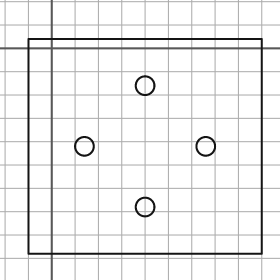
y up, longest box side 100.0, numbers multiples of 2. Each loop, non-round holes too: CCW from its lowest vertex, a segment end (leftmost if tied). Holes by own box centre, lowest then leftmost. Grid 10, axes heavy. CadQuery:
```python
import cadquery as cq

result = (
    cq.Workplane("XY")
    .moveTo(-10.0, -88.0)
    .lineTo(90.0, -88.0)
    .lineTo(90.0, 4.0)
    .lineTo(-10.0, 4.0)
    .close()
    .moveTo(40.0, -68.0)
    .circle(4.0)
    .moveTo(14.0, -42.0)
    .circle(4.0)
    .moveTo(66.0, -42.0)
    .circle(4.0)
    .moveTo(40.0, -16.0)
    .circle(4.0)
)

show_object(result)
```